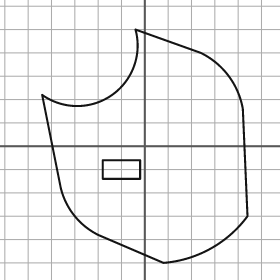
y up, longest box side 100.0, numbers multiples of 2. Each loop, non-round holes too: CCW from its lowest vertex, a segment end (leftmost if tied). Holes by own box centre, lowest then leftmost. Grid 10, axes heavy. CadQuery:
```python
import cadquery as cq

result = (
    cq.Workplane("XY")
    .moveTo(8.0, -50.0)
    .threePointArc((28.0, -44.0), (44.0, -30.0))
    .lineTo(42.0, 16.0)
    .threePointArc((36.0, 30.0), (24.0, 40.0))
    .lineTo(-4.0, 50.0)
    .threePointArc((-14.0, 22.0), (-44.0, 22.0))
    .lineTo(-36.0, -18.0)
    .threePointArc((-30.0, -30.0), (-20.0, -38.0))
    .close()
    .moveTo(-18.0, -14.0)
    .lineTo(-2.0, -14.0)
    .lineTo(-2.0, -6.0)
    .lineTo(-18.0, -6.0)
    .close()
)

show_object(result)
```